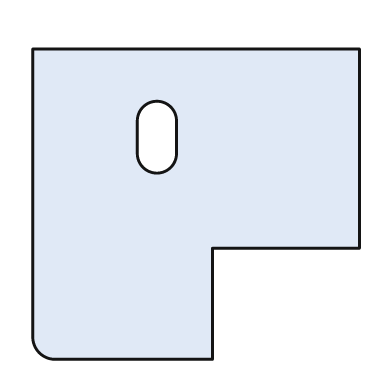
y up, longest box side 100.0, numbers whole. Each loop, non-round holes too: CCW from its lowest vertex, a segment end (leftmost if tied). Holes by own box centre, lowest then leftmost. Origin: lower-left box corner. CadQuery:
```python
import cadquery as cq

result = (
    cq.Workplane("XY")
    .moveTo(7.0, 0.0)
    .lineTo(55.0, 0.0)
    .lineTo(55.0, 34.0)
    .lineTo(100.0, 34.0)
    .lineTo(100.0, 95.0)
    .lineTo(0.0, 95.0)
    .lineTo(0.0, 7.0)
    .threePointArc((2.0, 2.0), (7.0, 0.0))
    .close()
    .moveTo(32.0, 63.0)
    .threePointArc((38.0, 57.0), (44.0, 63.0))
    .lineTo(44.0, 73.0)
    .threePointArc((38.0, 79.0), (32.0, 73.0))
    .close()
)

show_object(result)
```